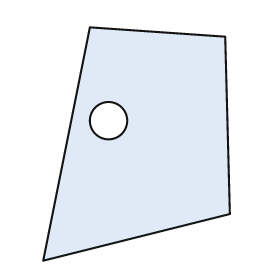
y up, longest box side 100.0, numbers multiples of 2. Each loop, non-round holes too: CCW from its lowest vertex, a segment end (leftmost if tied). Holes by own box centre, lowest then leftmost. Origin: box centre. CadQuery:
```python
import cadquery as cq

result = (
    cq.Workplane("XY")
    .moveTo(-40.0, -50.0)
    .lineTo(40.0, -30.0)
    .lineTo(38.0, 46.0)
    .lineTo(-20.0, 50.0)
    .close()
    .moveTo(-12.0, 10.0)
    .circle(8.0)
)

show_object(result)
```